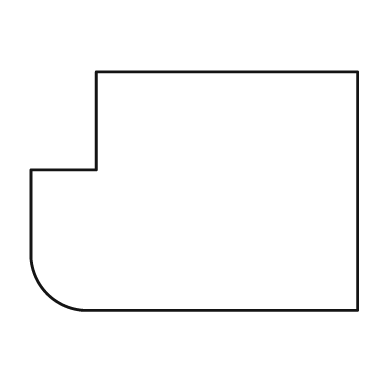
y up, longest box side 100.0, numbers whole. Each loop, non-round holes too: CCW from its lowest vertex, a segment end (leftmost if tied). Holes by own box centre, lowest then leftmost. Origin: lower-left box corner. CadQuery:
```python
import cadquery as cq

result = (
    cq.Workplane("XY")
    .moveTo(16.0, 0.0)
    .lineTo(100.0, 0.0)
    .lineTo(100.0, 73.0)
    .lineTo(20.0, 73.0)
    .lineTo(20.0, 43.0)
    .lineTo(0.0, 43.0)
    .lineTo(0.0, 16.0)
    .threePointArc((5.0, 5.0), (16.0, 0.0))
    .close()
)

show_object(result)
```